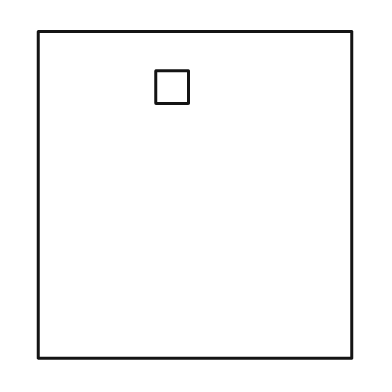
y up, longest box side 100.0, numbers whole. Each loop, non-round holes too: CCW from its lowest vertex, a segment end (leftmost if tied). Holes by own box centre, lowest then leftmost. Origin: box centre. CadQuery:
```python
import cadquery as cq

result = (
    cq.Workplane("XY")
    .moveTo(-48.0, -50.0)
    .lineTo(48.0, -50.0)
    .lineTo(48.0, 50.0)
    .lineTo(-48.0, 50.0)
    .close()
    .moveTo(-12.0, 28.0)
    .lineTo(-2.0, 28.0)
    .lineTo(-2.0, 38.0)
    .lineTo(-12.0, 38.0)
    .close()
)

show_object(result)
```